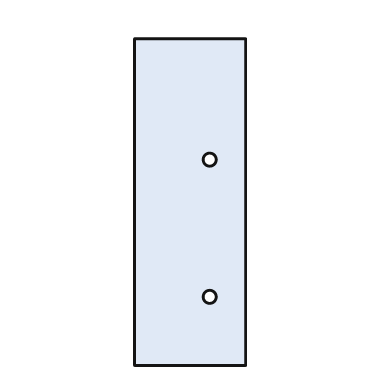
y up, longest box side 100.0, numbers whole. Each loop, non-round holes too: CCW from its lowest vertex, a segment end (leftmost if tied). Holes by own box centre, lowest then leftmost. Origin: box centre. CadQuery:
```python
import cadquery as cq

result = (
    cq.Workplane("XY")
    .moveTo(-17.0, -50.0)
    .lineTo(17.0, -50.0)
    .lineTo(17.0, 50.0)
    .lineTo(-17.0, 50.0)
    .close()
    .moveTo(6.0, -29.0)
    .circle(2.0)
    .moveTo(6.0, 13.0)
    .circle(2.0)
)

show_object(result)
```